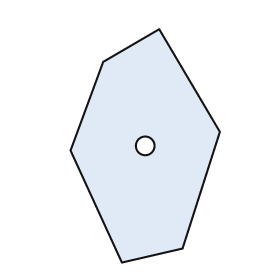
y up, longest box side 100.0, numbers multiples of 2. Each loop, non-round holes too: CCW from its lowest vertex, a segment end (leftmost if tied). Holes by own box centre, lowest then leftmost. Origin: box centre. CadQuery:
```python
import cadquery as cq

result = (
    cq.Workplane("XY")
    .moveTo(-10.0, -50.0)
    .lineTo(16.0, -44.0)
    .lineTo(32.0, 6.0)
    .lineTo(6.0, 50.0)
    .lineTo(-18.0, 36.0)
    .lineTo(-32.0, -2.0)
    .close()
    .moveTo(0.0, 0.0)
    .circle(4.0)
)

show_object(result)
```